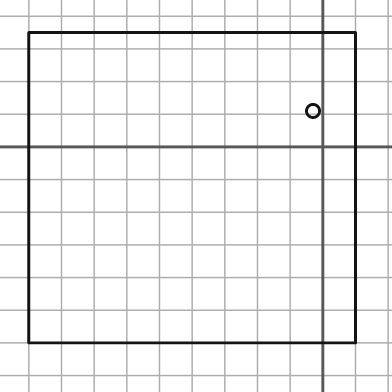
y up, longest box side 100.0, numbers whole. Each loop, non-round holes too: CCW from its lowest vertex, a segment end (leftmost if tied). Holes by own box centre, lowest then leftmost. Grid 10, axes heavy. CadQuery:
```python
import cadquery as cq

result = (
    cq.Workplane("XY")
    .moveTo(-90.0, -60.0)
    .lineTo(10.0, -60.0)
    .lineTo(10.0, 35.0)
    .lineTo(-90.0, 35.0)
    .close()
    .moveTo(-3.0, 11.0)
    .circle(2.0)
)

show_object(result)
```